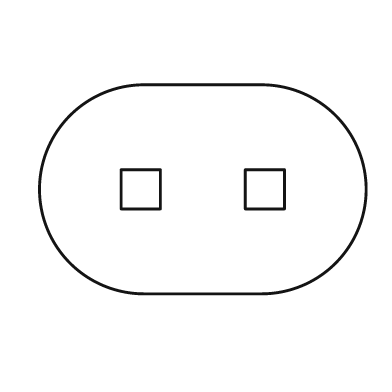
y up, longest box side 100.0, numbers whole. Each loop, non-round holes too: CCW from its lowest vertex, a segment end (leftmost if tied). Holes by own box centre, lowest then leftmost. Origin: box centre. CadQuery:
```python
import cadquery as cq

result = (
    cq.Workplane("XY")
    .moveTo(-18.0, -32.0)
    .lineTo(18.0, -32.0)
    .threePointArc((50.0, 0.0), (18.0, 32.0))
    .lineTo(-18.0, 32.0)
    .threePointArc((-50.0, 0.0), (-18.0, -32.0))
    .close()
    .moveTo(-25.0, -6.0)
    .lineTo(-13.0, -6.0)
    .lineTo(-13.0, 6.0)
    .lineTo(-25.0, 6.0)
    .close()
    .moveTo(13.0, -6.0)
    .lineTo(25.0, -6.0)
    .lineTo(25.0, 6.0)
    .lineTo(13.0, 6.0)
    .close()
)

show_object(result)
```